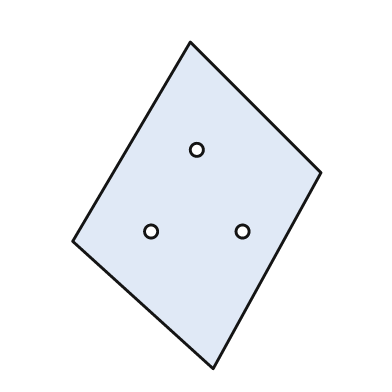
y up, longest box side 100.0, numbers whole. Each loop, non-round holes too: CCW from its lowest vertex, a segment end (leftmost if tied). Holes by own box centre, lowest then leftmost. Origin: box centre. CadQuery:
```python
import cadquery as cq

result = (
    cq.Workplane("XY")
    .moveTo(5.0, -50.0)
    .lineTo(38.0, 10.0)
    .lineTo(-2.0, 50.0)
    .lineTo(-38.0, -11.0)
    .close()
    .moveTo(-14.0, -8.0)
    .circle(2.0)
    .moveTo(14.0, -8.0)
    .circle(2.0)
    .moveTo(0.0, 17.0)
    .circle(2.0)
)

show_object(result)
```